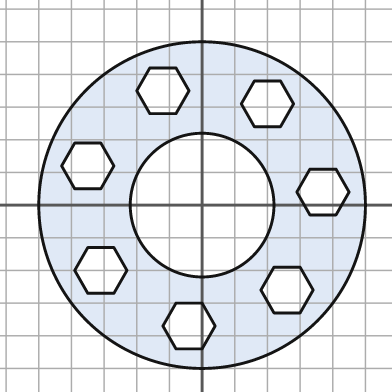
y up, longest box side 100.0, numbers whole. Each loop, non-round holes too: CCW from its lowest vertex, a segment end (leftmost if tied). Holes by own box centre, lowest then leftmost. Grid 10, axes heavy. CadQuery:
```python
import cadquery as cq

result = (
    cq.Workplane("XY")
    .moveTo(0.0, 0.0)
    .circle(50.0)
    .moveTo(-8.0, -44.0)
    .lineTo(0.0, -44.0)
    .lineTo(4.0, -37.0)
    .lineTo(0.0, -30.0)
    .lineTo(-8.0, -30.0)
    .lineTo(-12.0, -37.0)
    .close()
    .moveTo(22.0, -33.0)
    .lineTo(30.0, -33.0)
    .lineTo(34.0, -26.0)
    .lineTo(30.0, -19.0)
    .lineTo(22.0, -19.0)
    .lineTo(18.0, -26.0)
    .close()
    .moveTo(-35.0, -27.0)
    .lineTo(-27.0, -27.0)
    .lineTo(-23.0, -20.0)
    .lineTo(-27.0, -13.0)
    .lineTo(-35.0, -13.0)
    .lineTo(-39.0, -20.0)
    .close()
    .moveTo(0.0, 0.0)
    .circle(22.0)
    .moveTo(33.0, -3.0)
    .lineTo(41.0, -3.0)
    .lineTo(45.0, 4.0)
    .lineTo(41.0, 11.0)
    .lineTo(33.0, 11.0)
    .lineTo(29.0, 4.0)
    .close()
    .moveTo(-39.0, 5.0)
    .lineTo(-31.0, 5.0)
    .lineTo(-27.0, 12.0)
    .lineTo(-31.0, 19.0)
    .lineTo(-39.0, 19.0)
    .lineTo(-43.0, 12.0)
    .close()
    .moveTo(16.0, 24.0)
    .lineTo(24.0, 24.0)
    .lineTo(28.0, 31.0)
    .lineTo(24.0, 38.0)
    .lineTo(16.0, 38.0)
    .lineTo(12.0, 31.0)
    .close()
    .moveTo(-16.0, 28.0)
    .lineTo(-8.0, 28.0)
    .lineTo(-4.0, 35.0)
    .lineTo(-8.0, 42.0)
    .lineTo(-16.0, 42.0)
    .lineTo(-20.0, 35.0)
    .close()
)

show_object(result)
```